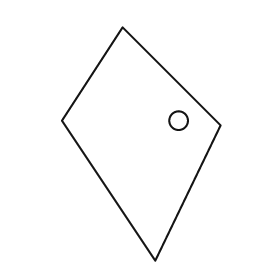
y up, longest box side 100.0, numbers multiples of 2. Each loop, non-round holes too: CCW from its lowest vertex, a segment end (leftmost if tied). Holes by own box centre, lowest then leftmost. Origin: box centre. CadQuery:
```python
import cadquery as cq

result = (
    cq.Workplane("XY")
    .moveTo(6.0, -50.0)
    .lineTo(34.0, 8.0)
    .lineTo(-8.0, 50.0)
    .lineTo(-34.0, 10.0)
    .close()
    .moveTo(16.0, 10.0)
    .circle(4.0)
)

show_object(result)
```